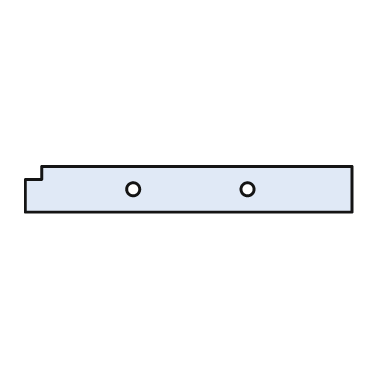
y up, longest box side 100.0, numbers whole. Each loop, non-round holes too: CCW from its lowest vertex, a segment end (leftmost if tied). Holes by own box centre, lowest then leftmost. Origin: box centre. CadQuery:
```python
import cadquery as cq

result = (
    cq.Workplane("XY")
    .moveTo(-50.0, -7.0)
    .lineTo(50.0, -7.0)
    .lineTo(50.0, 7.0)
    .lineTo(-45.0, 7.0)
    .lineTo(-45.0, 3.0)
    .lineTo(-50.0, 3.0)
    .close()
    .moveTo(-17.0, 0.0)
    .circle(2.0)
    .moveTo(18.0, 0.0)
    .circle(2.0)
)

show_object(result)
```